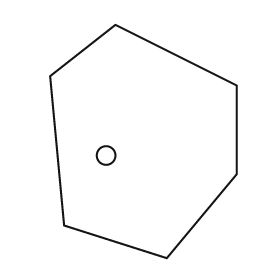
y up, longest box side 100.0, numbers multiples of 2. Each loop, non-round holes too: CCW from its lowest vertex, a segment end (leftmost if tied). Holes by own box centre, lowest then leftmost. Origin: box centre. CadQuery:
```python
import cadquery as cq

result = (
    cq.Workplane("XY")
    .moveTo(10.0, -50.0)
    .lineTo(40.0, -14.0)
    .lineTo(40.0, 24.0)
    .lineTo(-12.0, 50.0)
    .lineTo(-40.0, 28.0)
    .lineTo(-34.0, -36.0)
    .close()
    .moveTo(-16.0, -6.0)
    .circle(4.0)
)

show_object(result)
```